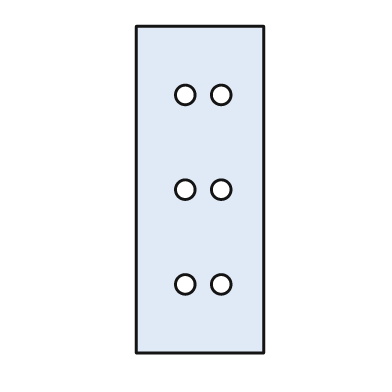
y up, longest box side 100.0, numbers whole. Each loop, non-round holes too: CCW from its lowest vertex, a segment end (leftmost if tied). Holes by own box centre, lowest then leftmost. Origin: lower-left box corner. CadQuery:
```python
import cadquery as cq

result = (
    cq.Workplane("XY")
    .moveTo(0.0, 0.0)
    .lineTo(39.0, 0.0)
    .lineTo(39.0, 100.0)
    .lineTo(0.0, 100.0)
    .close()
    .moveTo(15.0, 21.0)
    .circle(3.0)
    .moveTo(26.0, 21.0)
    .circle(3.0)
    .moveTo(15.0, 50.0)
    .circle(3.0)
    .moveTo(26.0, 50.0)
    .circle(3.0)
    .moveTo(15.0, 79.0)
    .circle(3.0)
    .moveTo(26.0, 79.0)
    .circle(3.0)
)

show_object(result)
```